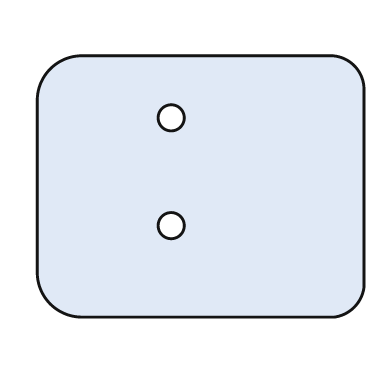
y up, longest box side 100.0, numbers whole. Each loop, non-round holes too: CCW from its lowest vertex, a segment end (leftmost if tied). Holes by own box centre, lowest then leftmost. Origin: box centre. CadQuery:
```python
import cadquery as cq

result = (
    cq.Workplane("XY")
    .moveTo(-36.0, -40.0)
    .lineTo(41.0, -40.0)
    .threePointArc((47.0, -37.0), (50.0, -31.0))
    .lineTo(50.0, 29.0)
    .threePointArc((47.0, 37.0), (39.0, 40.0))
    .lineTo(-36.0, 40.0)
    .threePointArc((-46.0, 36.0), (-50.0, 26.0))
    .lineTo(-50.0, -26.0)
    .threePointArc((-46.0, -36.0), (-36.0, -40.0))
    .close()
    .moveTo(-9.0, -12.0)
    .circle(4.0)
    .moveTo(-9.0, 21.0)
    .circle(4.0)
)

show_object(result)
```